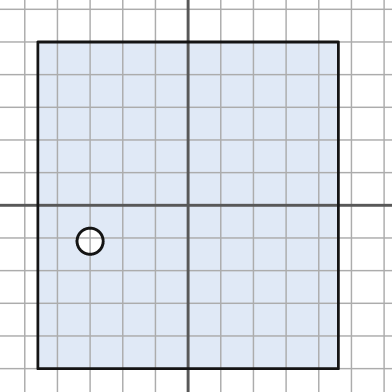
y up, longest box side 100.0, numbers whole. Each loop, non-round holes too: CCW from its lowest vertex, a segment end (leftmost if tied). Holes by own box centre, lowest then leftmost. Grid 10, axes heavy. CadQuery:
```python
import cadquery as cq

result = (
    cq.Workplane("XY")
    .moveTo(-46.0, -50.0)
    .lineTo(46.0, -50.0)
    .lineTo(46.0, 50.0)
    .lineTo(-46.0, 50.0)
    .close()
    .moveTo(-30.0, -11.0)
    .circle(4.0)
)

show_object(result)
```